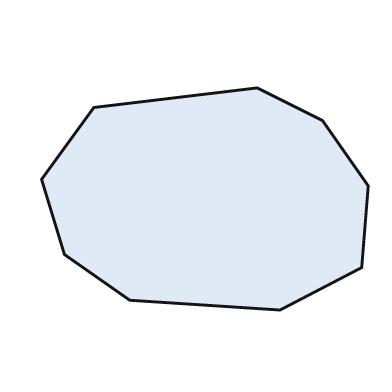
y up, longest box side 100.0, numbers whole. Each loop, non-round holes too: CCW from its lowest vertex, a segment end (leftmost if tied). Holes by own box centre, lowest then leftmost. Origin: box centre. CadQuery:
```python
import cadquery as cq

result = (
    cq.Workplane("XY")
    .moveTo(23.0, -34.0)
    .lineTo(48.0, -21.0)
    .lineTo(50.0, 4.0)
    .lineTo(36.0, 24.0)
    .lineTo(16.0, 34.0)
    .lineTo(-34.0, 28.0)
    .lineTo(-50.0, 6.0)
    .lineTo(-43.0, -17.0)
    .lineTo(-23.0, -31.0)
    .close()
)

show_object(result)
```